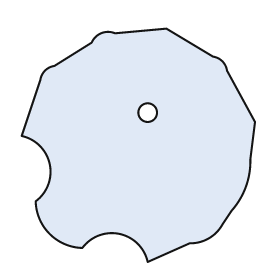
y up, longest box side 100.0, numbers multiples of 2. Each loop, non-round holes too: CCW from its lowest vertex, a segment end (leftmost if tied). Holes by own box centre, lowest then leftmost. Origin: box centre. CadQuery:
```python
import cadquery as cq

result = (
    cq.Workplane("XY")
    .moveTo(4.0, -50.0)
    .lineTo(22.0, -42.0)
    .threePointArc((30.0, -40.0), (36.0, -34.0))
    .lineTo(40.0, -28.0)
    .threePointArc((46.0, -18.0), (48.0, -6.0))
    .lineTo(50.0, 10.0)
    .lineTo(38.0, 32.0)
    .threePointArc((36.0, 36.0), (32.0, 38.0))
    .lineTo(12.0, 50.0)
    .lineTo(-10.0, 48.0)
    .threePointArc((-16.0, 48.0), (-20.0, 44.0))
    .lineTo(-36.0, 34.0)
    .threePointArc((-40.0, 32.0), (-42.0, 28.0))
    .lineTo(-50.0, 4.0)
    .threePointArc((-38.0, -8.0), (-44.0, -24.0))
    .threePointArc((-38.0, -38.0), (-24.0, -44.0))
    .threePointArc((-8.0, -38.0), (4.0, -50.0))
    .close()
    .moveTo(4.0, 14.0)
    .circle(4.0)
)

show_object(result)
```